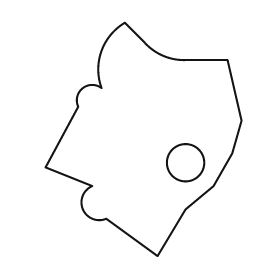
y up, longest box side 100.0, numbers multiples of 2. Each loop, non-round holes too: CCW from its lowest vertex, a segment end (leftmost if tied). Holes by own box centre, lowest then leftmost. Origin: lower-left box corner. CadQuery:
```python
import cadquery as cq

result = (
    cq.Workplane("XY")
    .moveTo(48.0, 0.0)
    .lineTo(60.0, 20.0)
    .lineTo(72.0, 30.0)
    .lineTo(80.0, 44.0)
    .lineTo(84.0, 58.0)
    .lineTo(78.0, 84.0)
    .lineTo(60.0, 84.0)
    .threePointArc((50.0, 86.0), (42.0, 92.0))
    .lineTo(34.0, 100.0)
    .threePointArc((24.0, 88.0), (24.0, 72.0))
    .threePointArc((16.0, 72.0), (14.0, 64.0))
    .lineTo(0.0, 38.0)
    .lineTo(20.0, 30.0)
    .threePointArc((16.0, 20.0), (26.0, 16.0))
    .close()
    .moveTo(60.0, 40.0)
    .circle(8.0)
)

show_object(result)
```